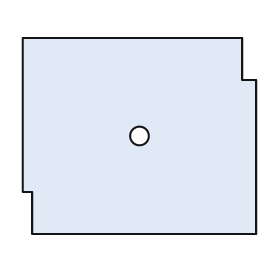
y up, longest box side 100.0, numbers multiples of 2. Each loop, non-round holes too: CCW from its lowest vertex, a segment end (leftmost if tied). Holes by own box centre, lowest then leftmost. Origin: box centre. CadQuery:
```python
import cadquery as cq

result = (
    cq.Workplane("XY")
    .moveTo(-46.0, -42.0)
    .lineTo(50.0, -42.0)
    .lineTo(50.0, 24.0)
    .lineTo(44.0, 24.0)
    .lineTo(44.0, 42.0)
    .lineTo(-50.0, 42.0)
    .lineTo(-50.0, -24.0)
    .lineTo(-46.0, -24.0)
    .close()
    .moveTo(0.0, 0.0)
    .circle(4.0)
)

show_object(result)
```